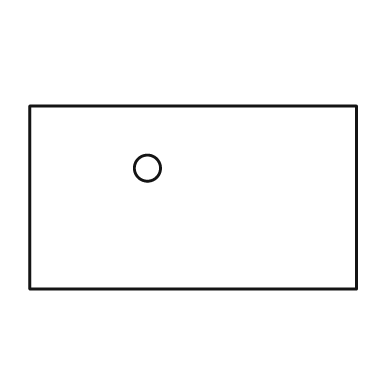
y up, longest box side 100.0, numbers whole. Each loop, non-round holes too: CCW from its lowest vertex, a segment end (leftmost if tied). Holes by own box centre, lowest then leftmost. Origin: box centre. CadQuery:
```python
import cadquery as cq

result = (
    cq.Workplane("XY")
    .moveTo(-50.0, -28.0)
    .lineTo(50.0, -28.0)
    .lineTo(50.0, 28.0)
    .lineTo(-50.0, 28.0)
    .close()
    .moveTo(-14.0, 9.0)
    .circle(4.0)
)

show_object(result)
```